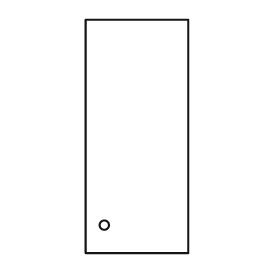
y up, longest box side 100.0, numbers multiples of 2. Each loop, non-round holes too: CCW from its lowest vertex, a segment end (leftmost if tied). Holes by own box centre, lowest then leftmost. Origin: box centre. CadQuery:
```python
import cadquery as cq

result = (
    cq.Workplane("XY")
    .moveTo(-22.0, -50.0)
    .lineTo(22.0, -50.0)
    .lineTo(22.0, 50.0)
    .lineTo(-22.0, 50.0)
    .close()
    .moveTo(-14.0, -38.0)
    .circle(2.0)
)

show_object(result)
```